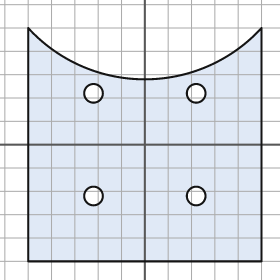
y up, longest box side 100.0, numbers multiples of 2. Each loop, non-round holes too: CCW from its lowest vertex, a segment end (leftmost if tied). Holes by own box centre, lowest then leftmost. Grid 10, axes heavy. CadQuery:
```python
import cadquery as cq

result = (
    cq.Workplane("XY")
    .moveTo(-50.0, -50.0)
    .lineTo(50.0, -50.0)
    .lineTo(50.0, 50.0)
    .threePointArc((0.0, 28.0), (-50.0, 50.0))
    .close()
    .moveTo(-22.0, -22.0)
    .circle(4.0)
    .moveTo(22.0, -22.0)
    .circle(4.0)
    .moveTo(-22.0, 22.0)
    .circle(4.0)
    .moveTo(22.0, 22.0)
    .circle(4.0)
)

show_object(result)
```